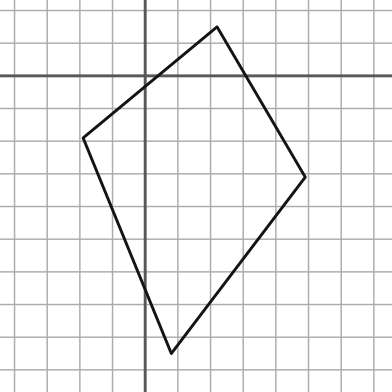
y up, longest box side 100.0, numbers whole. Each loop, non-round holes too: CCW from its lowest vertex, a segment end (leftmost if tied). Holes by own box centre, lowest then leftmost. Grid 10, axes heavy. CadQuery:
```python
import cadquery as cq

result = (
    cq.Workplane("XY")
    .moveTo(8.0, -85.0)
    .lineTo(49.0, -31.0)
    .lineTo(22.0, 15.0)
    .lineTo(-19.0, -19.0)
    .close()
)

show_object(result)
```